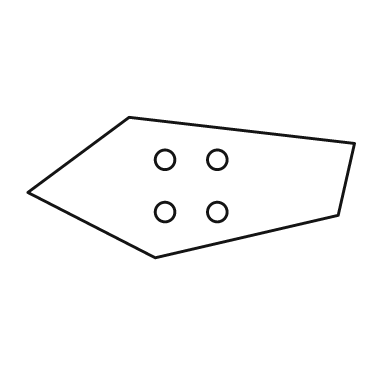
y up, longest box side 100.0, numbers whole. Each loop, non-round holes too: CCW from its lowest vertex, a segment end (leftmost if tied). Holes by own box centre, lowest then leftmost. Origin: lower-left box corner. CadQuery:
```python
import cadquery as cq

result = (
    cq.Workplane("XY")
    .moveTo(39.0, 0.0)
    .lineTo(95.0, 13.0)
    .lineTo(100.0, 35.0)
    .lineTo(31.0, 43.0)
    .lineTo(0.0, 20.0)
    .close()
    .moveTo(42.0, 14.0)
    .circle(3.0)
    .moveTo(58.0, 14.0)
    .circle(3.0)
    .moveTo(42.0, 30.0)
    .circle(3.0)
    .moveTo(58.0, 30.0)
    .circle(3.0)
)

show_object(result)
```